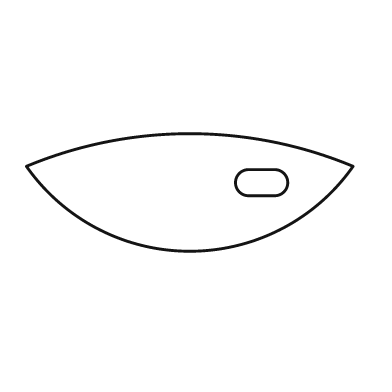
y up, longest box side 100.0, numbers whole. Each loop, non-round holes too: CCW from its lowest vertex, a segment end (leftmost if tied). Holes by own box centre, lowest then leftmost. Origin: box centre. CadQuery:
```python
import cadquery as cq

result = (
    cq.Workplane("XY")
    .moveTo(-50.0, 8.0)
    .threePointArc((0.0, -18.0), (50.0, 8.0))
    .threePointArc((0.0, 18.0), (-50.0, 8.0))
    .close()
    .moveTo(18.0, -1.0)
    .lineTo(26.0, -1.0)
    .threePointArc((30.0, 3.0), (26.0, 7.0))
    .lineTo(18.0, 7.0)
    .threePointArc((14.0, 3.0), (18.0, -1.0))
    .close()
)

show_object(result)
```